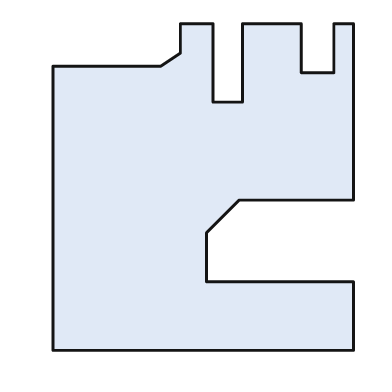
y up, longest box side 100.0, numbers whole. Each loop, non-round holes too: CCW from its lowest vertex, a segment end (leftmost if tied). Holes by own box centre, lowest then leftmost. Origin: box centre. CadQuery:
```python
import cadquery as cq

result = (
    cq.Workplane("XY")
    .moveTo(-46.0, -50.0)
    .lineTo(46.0, -50.0)
    .lineTo(46.0, -29.0)
    .lineTo(1.0, -29.0)
    .lineTo(1.0, -14.0)
    .lineTo(11.0, -4.0)
    .lineTo(46.0, -4.0)
    .lineTo(46.0, 50.0)
    .lineTo(40.0, 50.0)
    .lineTo(40.0, 35.0)
    .lineTo(30.0, 35.0)
    .lineTo(30.0, 50.0)
    .lineTo(12.0, 50.0)
    .lineTo(12.0, 26.0)
    .lineTo(3.0, 26.0)
    .lineTo(3.0, 50.0)
    .lineTo(-7.0, 50.0)
    .lineTo(-7.0, 41.0)
    .lineTo(-13.0, 37.0)
    .lineTo(-46.0, 37.0)
    .close()
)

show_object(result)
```